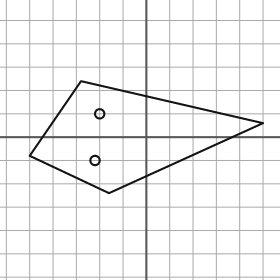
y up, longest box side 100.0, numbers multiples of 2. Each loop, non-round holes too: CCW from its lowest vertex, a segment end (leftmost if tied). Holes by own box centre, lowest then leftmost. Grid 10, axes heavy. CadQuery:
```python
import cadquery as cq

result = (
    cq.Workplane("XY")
    .moveTo(-16.0, -24.0)
    .lineTo(50.0, 6.0)
    .lineTo(-28.0, 24.0)
    .lineTo(-50.0, -8.0)
    .close()
    .moveTo(-22.0, -10.0)
    .circle(2.0)
    .moveTo(-20.0, 10.0)
    .circle(2.0)
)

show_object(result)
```